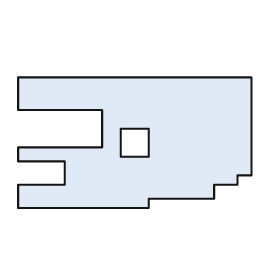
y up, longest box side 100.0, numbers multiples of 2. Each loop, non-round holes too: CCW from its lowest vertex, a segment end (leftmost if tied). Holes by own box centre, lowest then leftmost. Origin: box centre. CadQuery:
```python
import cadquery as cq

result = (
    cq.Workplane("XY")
    .moveTo(-50.0, -28.0)
    .lineTo(6.0, -28.0)
    .lineTo(6.0, -24.0)
    .lineTo(34.0, -24.0)
    .lineTo(34.0, -18.0)
    .lineTo(44.0, -18.0)
    .lineTo(44.0, -14.0)
    .lineTo(50.0, -14.0)
    .lineTo(50.0, 28.0)
    .lineTo(-50.0, 28.0)
    .lineTo(-50.0, 14.0)
    .lineTo(-14.0, 14.0)
    .lineTo(-14.0, -2.0)
    .lineTo(-50.0, -2.0)
    .lineTo(-50.0, -8.0)
    .lineTo(-30.0, -8.0)
    .lineTo(-30.0, -18.0)
    .lineTo(-50.0, -18.0)
    .close()
    .moveTo(-6.0, -6.0)
    .lineTo(6.0, -6.0)
    .lineTo(6.0, 6.0)
    .lineTo(-6.0, 6.0)
    .close()
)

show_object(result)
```